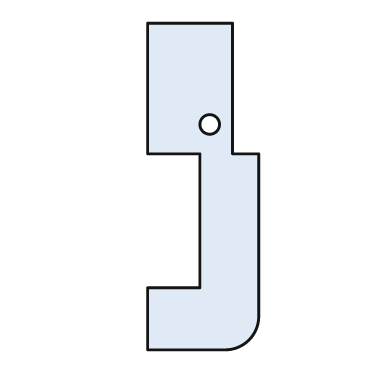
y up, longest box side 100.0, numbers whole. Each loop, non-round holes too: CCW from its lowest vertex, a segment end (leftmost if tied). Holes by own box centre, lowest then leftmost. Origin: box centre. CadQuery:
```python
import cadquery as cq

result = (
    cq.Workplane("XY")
    .moveTo(-17.0, -50.0)
    .lineTo(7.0, -50.0)
    .threePointArc((14.0, -47.0), (17.0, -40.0))
    .lineTo(17.0, 10.0)
    .lineTo(9.0, 10.0)
    .lineTo(9.0, 50.0)
    .lineTo(-17.0, 50.0)
    .lineTo(-17.0, 10.0)
    .lineTo(-1.0, 10.0)
    .lineTo(-1.0, -31.0)
    .lineTo(-17.0, -31.0)
    .close()
    .moveTo(2.0, 19.0)
    .circle(3.0)
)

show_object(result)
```